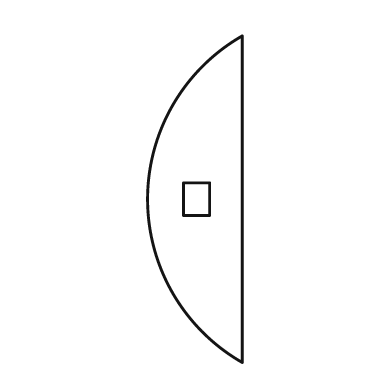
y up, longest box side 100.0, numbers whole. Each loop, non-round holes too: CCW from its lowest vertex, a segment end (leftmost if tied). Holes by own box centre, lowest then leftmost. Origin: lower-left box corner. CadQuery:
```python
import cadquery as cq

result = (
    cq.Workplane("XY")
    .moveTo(29.0, 0.0)
    .lineTo(29.0, 100.0)
    .threePointArc((0.0, 50.0), (29.0, 0.0))
    .close()
    .moveTo(11.0, 45.0)
    .lineTo(19.0, 45.0)
    .lineTo(19.0, 55.0)
    .lineTo(11.0, 55.0)
    .close()
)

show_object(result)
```